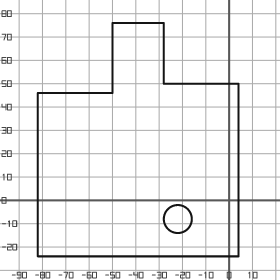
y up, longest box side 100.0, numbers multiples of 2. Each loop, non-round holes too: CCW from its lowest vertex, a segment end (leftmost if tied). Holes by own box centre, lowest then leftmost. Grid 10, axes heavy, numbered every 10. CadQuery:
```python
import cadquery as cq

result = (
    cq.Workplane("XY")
    .moveTo(-82.0, -24.0)
    .lineTo(4.0, -24.0)
    .lineTo(4.0, 50.0)
    .lineTo(-28.0, 50.0)
    .lineTo(-28.0, 76.0)
    .lineTo(-50.0, 76.0)
    .lineTo(-50.0, 46.0)
    .lineTo(-82.0, 46.0)
    .close()
    .moveTo(-22.0, -8.0)
    .circle(6.0)
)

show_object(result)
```